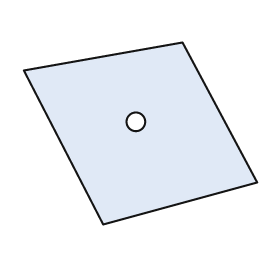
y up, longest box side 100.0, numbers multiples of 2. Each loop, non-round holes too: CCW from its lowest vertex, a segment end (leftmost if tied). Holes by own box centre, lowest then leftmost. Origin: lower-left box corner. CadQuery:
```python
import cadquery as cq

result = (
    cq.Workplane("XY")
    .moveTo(34.0, 0.0)
    .lineTo(100.0, 18.0)
    .lineTo(68.0, 78.0)
    .lineTo(0.0, 66.0)
    .close()
    .moveTo(48.0, 44.0)
    .circle(4.0)
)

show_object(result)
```